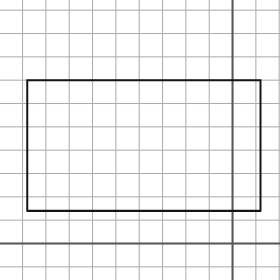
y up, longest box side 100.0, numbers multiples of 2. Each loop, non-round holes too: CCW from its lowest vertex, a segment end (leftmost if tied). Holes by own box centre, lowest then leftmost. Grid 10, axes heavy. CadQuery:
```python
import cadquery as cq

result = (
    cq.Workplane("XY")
    .moveTo(-88.0, 14.0)
    .lineTo(12.0, 14.0)
    .lineTo(12.0, 70.0)
    .lineTo(-88.0, 70.0)
    .close()
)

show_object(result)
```